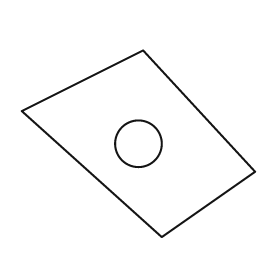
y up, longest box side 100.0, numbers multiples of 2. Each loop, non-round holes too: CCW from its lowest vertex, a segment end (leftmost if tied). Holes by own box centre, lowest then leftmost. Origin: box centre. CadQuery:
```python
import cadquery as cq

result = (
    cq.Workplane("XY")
    .moveTo(10.0, -40.0)
    .lineTo(50.0, -12.0)
    .lineTo(2.0, 40.0)
    .lineTo(-50.0, 14.0)
    .close()
    .moveTo(0.0, 0.0)
    .circle(10.0)
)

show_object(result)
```